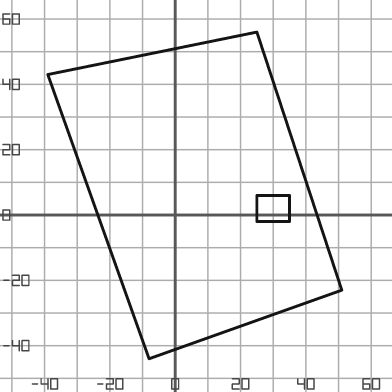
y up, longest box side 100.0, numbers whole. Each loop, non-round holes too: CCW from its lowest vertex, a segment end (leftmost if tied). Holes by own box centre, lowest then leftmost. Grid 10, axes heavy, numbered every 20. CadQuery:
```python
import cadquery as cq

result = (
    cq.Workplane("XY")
    .moveTo(-8.0, -44.0)
    .lineTo(51.0, -23.0)
    .lineTo(25.0, 56.0)
    .lineTo(-39.0, 43.0)
    .close()
    .moveTo(25.0, -2.0)
    .lineTo(35.0, -2.0)
    .lineTo(35.0, 6.0)
    .lineTo(25.0, 6.0)
    .close()
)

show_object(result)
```